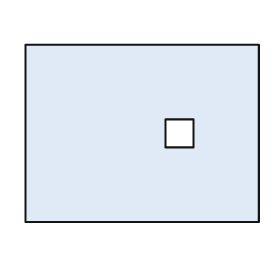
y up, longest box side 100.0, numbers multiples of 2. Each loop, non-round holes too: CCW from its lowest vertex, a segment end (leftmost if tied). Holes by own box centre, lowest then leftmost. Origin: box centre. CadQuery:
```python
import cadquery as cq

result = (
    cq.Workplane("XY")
    .moveTo(-50.0, -38.0)
    .lineTo(50.0, -38.0)
    .lineTo(50.0, 38.0)
    .lineTo(-50.0, 38.0)
    .close()
    .moveTo(10.0, -6.0)
    .lineTo(22.0, -6.0)
    .lineTo(22.0, 6.0)
    .lineTo(10.0, 6.0)
    .close()
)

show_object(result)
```